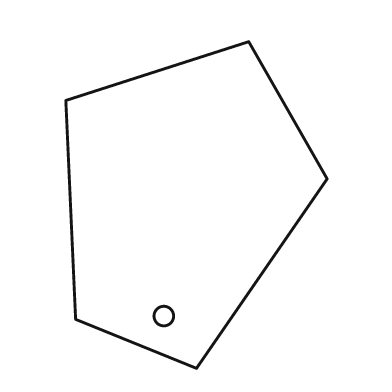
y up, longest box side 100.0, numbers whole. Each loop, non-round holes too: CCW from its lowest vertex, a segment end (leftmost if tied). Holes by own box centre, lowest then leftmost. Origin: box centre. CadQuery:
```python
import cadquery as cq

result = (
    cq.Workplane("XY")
    .moveTo(0.0, -50.0)
    .lineTo(40.0, 8.0)
    .lineTo(16.0, 50.0)
    .lineTo(-40.0, 32.0)
    .lineTo(-37.0, -35.0)
    .close()
    .moveTo(-10.0, -34.0)
    .circle(3.0)
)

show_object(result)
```